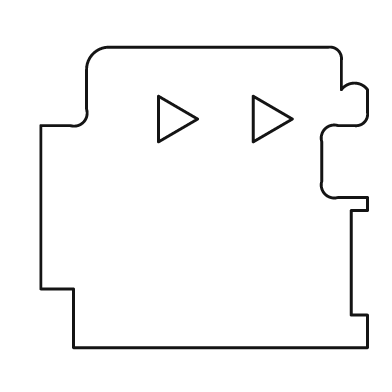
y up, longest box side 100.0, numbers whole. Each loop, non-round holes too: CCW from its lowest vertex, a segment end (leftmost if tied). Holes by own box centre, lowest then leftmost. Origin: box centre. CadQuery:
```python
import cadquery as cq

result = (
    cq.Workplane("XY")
    .moveTo(-40.0, -46.0)
    .lineTo(50.0, -46.0)
    .lineTo(50.0, -36.0)
    .lineTo(45.0, -36.0)
    .lineTo(45.0, -4.0)
    .lineTo(50.0, -4.0)
    .lineTo(50.0, 0.0)
    .lineTo(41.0, 0.0)
    .threePointArc((37.0, 1.0), (36.0, 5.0))
    .lineTo(36.0, 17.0)
    .threePointArc((37.0, 21.0), (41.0, 22.0))
    .lineTo(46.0, 22.0)
    .threePointArc((49.0, 23.0), (50.0, 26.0))
    .lineTo(50.0, 33.0)
    .threePointArc((46.0, 35.0), (42.0, 33.0))
    .lineTo(42.0, 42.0)
    .threePointArc((41.0, 45.0), (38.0, 46.0))
    .lineTo(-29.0, 46.0)
    .threePointArc((-34.0, 44.0), (-36.0, 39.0))
    .lineTo(-36.0, 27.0)
    .threePointArc((-37.0, 23.0), (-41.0, 22.0))
    .lineTo(-50.0, 22.0)
    .lineTo(-50.0, -28.0)
    .lineTo(-40.0, -28.0)
    .close()
    .moveTo(-14.0, 17.0)
    .lineTo(-2.0, 24.0)
    .lineTo(-14.0, 31.0)
    .close()
    .moveTo(15.0, 17.0)
    .lineTo(27.0, 24.0)
    .lineTo(15.0, 31.0)
    .close()
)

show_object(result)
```